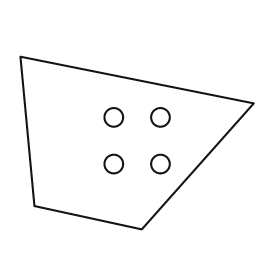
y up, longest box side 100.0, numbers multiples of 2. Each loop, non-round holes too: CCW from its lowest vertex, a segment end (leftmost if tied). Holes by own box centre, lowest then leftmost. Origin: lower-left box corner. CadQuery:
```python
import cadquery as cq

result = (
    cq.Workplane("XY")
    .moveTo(52.0, 0.0)
    .lineTo(100.0, 54.0)
    .lineTo(0.0, 74.0)
    .lineTo(6.0, 10.0)
    .close()
    .moveTo(40.0, 28.0)
    .circle(4.0)
    .moveTo(60.0, 28.0)
    .circle(4.0)
    .moveTo(40.0, 48.0)
    .circle(4.0)
    .moveTo(60.0, 48.0)
    .circle(4.0)
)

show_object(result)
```